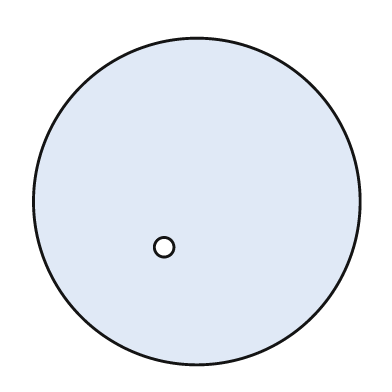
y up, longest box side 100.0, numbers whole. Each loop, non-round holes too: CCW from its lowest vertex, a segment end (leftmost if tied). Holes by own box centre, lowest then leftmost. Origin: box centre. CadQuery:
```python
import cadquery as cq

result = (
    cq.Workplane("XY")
    .moveTo(0.0, 0.0)
    .circle(50.0)
    .moveTo(-10.0, -14.0)
    .circle(3.0)
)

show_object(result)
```